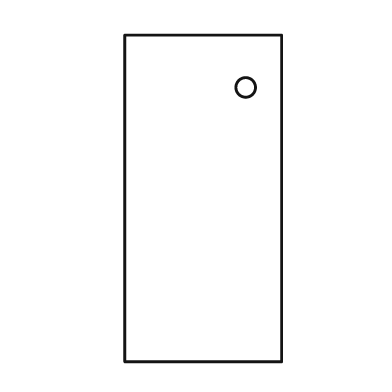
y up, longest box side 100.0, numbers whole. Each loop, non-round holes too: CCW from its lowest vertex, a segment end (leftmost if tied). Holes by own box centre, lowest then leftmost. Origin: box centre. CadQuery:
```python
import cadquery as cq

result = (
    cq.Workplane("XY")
    .moveTo(-24.0, -50.0)
    .lineTo(24.0, -50.0)
    .lineTo(24.0, 50.0)
    .lineTo(-24.0, 50.0)
    .close()
    .moveTo(13.0, 34.0)
    .circle(3.0)
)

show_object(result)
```